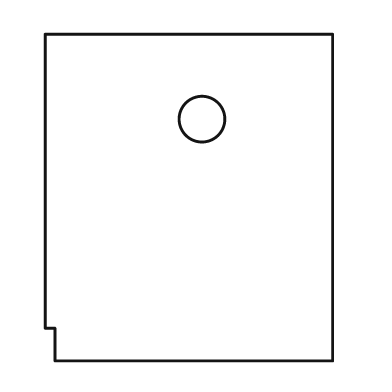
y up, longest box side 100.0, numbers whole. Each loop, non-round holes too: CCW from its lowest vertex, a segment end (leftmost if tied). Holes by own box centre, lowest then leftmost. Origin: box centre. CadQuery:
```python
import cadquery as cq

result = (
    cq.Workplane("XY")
    .moveTo(-41.0, -50.0)
    .lineTo(44.0, -50.0)
    .lineTo(44.0, 50.0)
    .lineTo(-44.0, 50.0)
    .lineTo(-44.0, -40.0)
    .lineTo(-41.0, -40.0)
    .close()
    .moveTo(4.0, 24.0)
    .circle(7.0)
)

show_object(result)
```